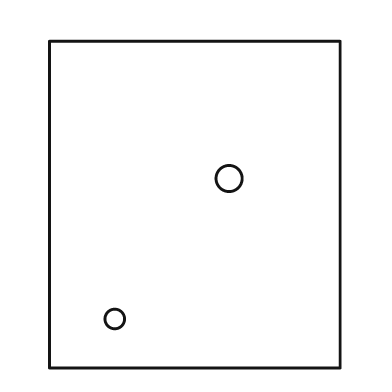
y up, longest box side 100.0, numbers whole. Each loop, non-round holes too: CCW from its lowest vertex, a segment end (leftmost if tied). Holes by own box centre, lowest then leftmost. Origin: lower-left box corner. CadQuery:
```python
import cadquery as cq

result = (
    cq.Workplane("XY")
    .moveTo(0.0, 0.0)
    .lineTo(89.0, 0.0)
    .lineTo(89.0, 100.0)
    .lineTo(0.0, 100.0)
    .close()
    .moveTo(20.0, 15.0)
    .circle(3.0)
    .moveTo(55.0, 58.0)
    .circle(4.0)
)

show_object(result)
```